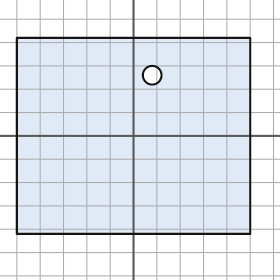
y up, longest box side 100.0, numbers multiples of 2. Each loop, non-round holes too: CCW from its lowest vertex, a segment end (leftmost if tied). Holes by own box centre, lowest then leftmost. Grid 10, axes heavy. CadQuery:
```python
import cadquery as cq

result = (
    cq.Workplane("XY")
    .moveTo(-50.0, -42.0)
    .lineTo(50.0, -42.0)
    .lineTo(50.0, 42.0)
    .lineTo(-50.0, 42.0)
    .close()
    .moveTo(8.0, 26.0)
    .circle(4.0)
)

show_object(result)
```